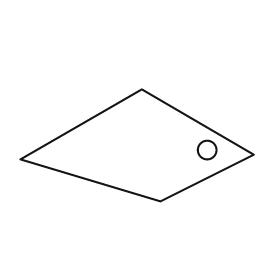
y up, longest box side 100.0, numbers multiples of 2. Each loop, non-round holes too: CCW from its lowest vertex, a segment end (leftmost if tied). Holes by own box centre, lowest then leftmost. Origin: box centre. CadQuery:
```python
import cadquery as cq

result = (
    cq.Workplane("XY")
    .moveTo(10.0, -24.0)
    .lineTo(50.0, -4.0)
    .lineTo(2.0, 24.0)
    .lineTo(-50.0, -6.0)
    .close()
    .moveTo(30.0, -2.0)
    .circle(4.0)
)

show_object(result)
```